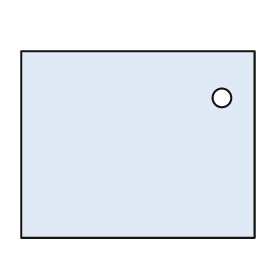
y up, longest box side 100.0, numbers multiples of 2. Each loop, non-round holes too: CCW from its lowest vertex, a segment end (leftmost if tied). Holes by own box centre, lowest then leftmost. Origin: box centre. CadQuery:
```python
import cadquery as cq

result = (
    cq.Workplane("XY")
    .moveTo(-50.0, -40.0)
    .lineTo(50.0, -40.0)
    .lineTo(50.0, 40.0)
    .lineTo(-50.0, 40.0)
    .close()
    .moveTo(36.0, 20.0)
    .circle(4.0)
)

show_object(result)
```